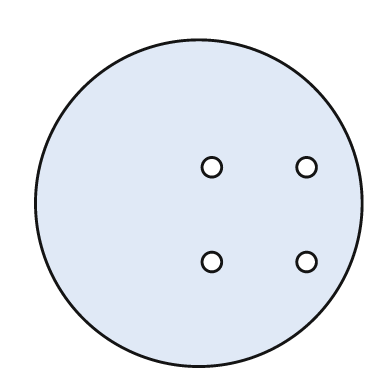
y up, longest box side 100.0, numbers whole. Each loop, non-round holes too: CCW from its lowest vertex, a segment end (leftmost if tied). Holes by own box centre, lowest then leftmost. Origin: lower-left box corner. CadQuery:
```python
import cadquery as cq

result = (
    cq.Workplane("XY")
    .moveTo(50.0, 50.0)
    .circle(50.0)
    .moveTo(54.0, 32.0)
    .circle(3.0)
    .moveTo(83.0, 32.0)
    .circle(3.0)
    .moveTo(54.0, 61.0)
    .circle(3.0)
    .moveTo(83.0, 61.0)
    .circle(3.0)
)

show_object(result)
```